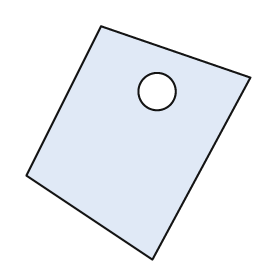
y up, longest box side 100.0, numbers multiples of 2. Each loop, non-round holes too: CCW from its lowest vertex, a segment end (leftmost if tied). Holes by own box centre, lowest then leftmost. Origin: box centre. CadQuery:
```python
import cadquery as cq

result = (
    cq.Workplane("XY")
    .moveTo(6.0, -50.0)
    .lineTo(48.0, 28.0)
    .lineTo(-16.0, 50.0)
    .lineTo(-48.0, -14.0)
    .close()
    .moveTo(8.0, 22.0)
    .circle(8.0)
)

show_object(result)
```